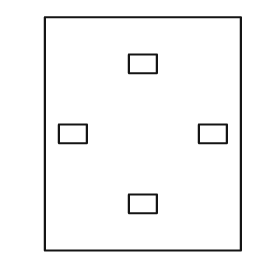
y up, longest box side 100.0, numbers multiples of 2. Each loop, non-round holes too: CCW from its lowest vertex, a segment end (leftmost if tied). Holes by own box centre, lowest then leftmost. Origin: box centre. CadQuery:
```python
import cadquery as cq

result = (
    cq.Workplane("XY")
    .moveTo(-42.0, -50.0)
    .lineTo(42.0, -50.0)
    .lineTo(42.0, 50.0)
    .lineTo(-42.0, 50.0)
    .close()
    .moveTo(-6.0, -34.0)
    .lineTo(6.0, -34.0)
    .lineTo(6.0, -26.0)
    .lineTo(-6.0, -26.0)
    .close()
    .moveTo(-36.0, -4.0)
    .lineTo(-24.0, -4.0)
    .lineTo(-24.0, 4.0)
    .lineTo(-36.0, 4.0)
    .close()
    .moveTo(24.0, -4.0)
    .lineTo(36.0, -4.0)
    .lineTo(36.0, 4.0)
    .lineTo(24.0, 4.0)
    .close()
    .moveTo(-6.0, 26.0)
    .lineTo(6.0, 26.0)
    .lineTo(6.0, 34.0)
    .lineTo(-6.0, 34.0)
    .close()
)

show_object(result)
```